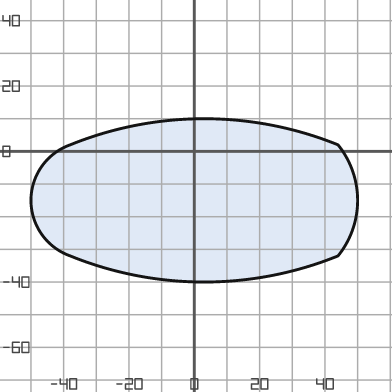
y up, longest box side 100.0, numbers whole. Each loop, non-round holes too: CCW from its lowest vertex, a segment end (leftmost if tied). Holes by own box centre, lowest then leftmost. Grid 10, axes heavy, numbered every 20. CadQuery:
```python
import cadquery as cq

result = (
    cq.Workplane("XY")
    .moveTo(-38.0, -32.0)
    .threePointArc((3.0, -40.0), (44.0, -32.0))
    .threePointArc((50.0, -15.0), (44.0, 2.0))
    .threePointArc((3.0, 10.0), (-38.0, 2.0))
    .threePointArc((-50.0, -15.0), (-38.0, -32.0))
    .close()
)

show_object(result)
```